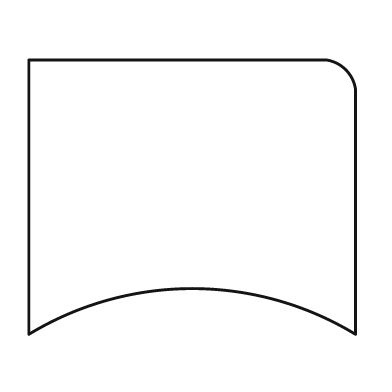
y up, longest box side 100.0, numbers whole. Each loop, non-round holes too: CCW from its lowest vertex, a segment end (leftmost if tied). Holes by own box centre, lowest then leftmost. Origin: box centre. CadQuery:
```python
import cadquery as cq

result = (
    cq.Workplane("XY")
    .moveTo(-50.0, -42.0)
    .threePointArc((0.0, -28.0), (50.0, -42.0))
    .lineTo(50.0, 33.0)
    .threePointArc((47.0, 39.0), (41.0, 42.0))
    .lineTo(-50.0, 42.0)
    .close()
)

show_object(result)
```